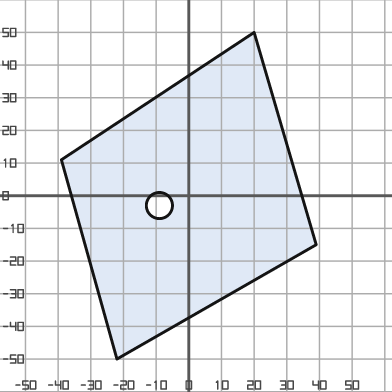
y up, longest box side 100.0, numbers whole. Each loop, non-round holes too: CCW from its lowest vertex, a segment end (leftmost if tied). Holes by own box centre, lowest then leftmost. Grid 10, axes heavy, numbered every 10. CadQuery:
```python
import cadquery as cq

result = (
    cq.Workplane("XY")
    .moveTo(-22.0, -50.0)
    .lineTo(39.0, -15.0)
    .lineTo(20.0, 50.0)
    .lineTo(-39.0, 11.0)
    .close()
    .moveTo(-9.0, -3.0)
    .circle(4.0)
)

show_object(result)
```